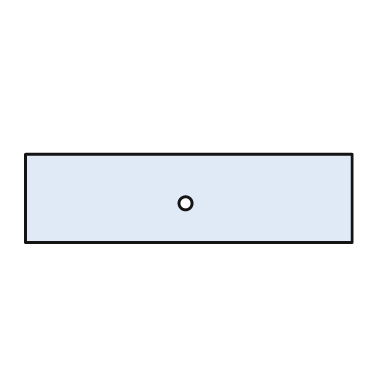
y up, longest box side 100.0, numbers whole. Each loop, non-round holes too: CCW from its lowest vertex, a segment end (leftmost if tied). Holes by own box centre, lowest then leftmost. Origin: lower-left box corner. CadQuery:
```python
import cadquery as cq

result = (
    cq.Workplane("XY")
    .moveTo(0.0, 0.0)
    .lineTo(100.0, 0.0)
    .lineTo(100.0, 27.0)
    .lineTo(0.0, 27.0)
    .close()
    .moveTo(49.0, 12.0)
    .circle(2.0)
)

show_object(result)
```